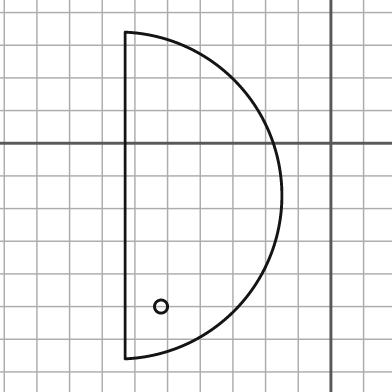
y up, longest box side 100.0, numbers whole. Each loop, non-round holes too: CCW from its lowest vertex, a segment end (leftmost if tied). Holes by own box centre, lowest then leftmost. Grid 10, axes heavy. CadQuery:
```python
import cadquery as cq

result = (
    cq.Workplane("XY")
    .moveTo(-63.0, -66.0)
    .threePointArc((-15.0, -16.0), (-63.0, 34.0))
    .close()
    .moveTo(-52.0, -50.0)
    .circle(2.0)
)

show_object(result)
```